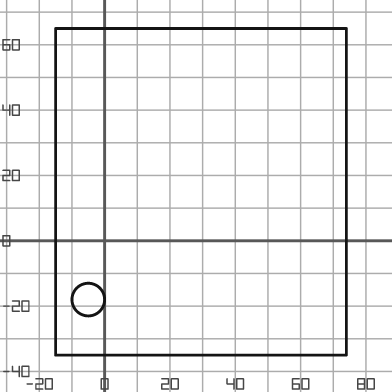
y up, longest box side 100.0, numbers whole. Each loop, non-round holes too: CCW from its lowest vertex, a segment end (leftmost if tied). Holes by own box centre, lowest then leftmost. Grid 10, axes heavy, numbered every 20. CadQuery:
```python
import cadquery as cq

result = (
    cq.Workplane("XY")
    .moveTo(-15.0, -35.0)
    .lineTo(74.0, -35.0)
    .lineTo(74.0, 65.0)
    .lineTo(-15.0, 65.0)
    .close()
    .moveTo(-5.0, -18.0)
    .circle(5.0)
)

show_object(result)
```